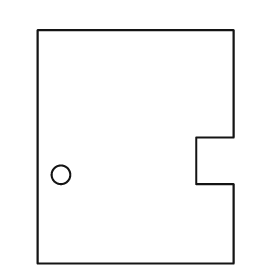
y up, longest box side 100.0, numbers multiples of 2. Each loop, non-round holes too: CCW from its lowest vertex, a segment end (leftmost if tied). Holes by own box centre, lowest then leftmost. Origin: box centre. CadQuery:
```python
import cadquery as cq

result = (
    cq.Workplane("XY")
    .moveTo(-42.0, -50.0)
    .lineTo(42.0, -50.0)
    .lineTo(42.0, -16.0)
    .lineTo(26.0, -16.0)
    .lineTo(26.0, 4.0)
    .lineTo(42.0, 4.0)
    .lineTo(42.0, 50.0)
    .lineTo(-42.0, 50.0)
    .close()
    .moveTo(-32.0, -12.0)
    .circle(4.0)
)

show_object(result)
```